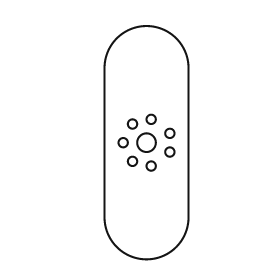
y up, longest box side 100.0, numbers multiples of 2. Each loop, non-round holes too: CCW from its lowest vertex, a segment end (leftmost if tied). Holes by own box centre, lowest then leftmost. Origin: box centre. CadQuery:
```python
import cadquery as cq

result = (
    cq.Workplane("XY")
    .moveTo(-18.0, -32.0)
    .threePointArc((0.0, -50.0), (18.0, -32.0))
    .lineTo(18.0, 32.0)
    .threePointArc((0.0, 50.0), (-18.0, 32.0))
    .close()
    .moveTo(2.0, -10.0)
    .circle(2.0)
    .moveTo(-6.0, -8.0)
    .circle(2.0)
    .moveTo(10.0, -4.0)
    .circle(2.0)
    .moveTo(-10.0, 0.0)
    .circle(2.0)
    .moveTo(0.0, 0.0)
    .circle(4.0)
    .moveTo(10.0, 4.0)
    .circle(2.0)
    .moveTo(-6.0, 8.0)
    .circle(2.0)
    .moveTo(2.0, 10.0)
    .circle(2.0)
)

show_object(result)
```